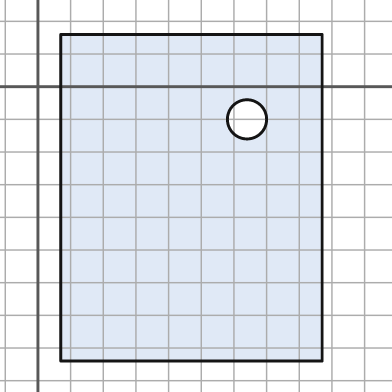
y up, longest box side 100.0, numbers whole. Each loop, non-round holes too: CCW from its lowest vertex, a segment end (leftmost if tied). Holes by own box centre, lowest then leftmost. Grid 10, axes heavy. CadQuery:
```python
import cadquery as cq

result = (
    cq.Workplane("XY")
    .moveTo(7.0, -84.0)
    .lineTo(87.0, -84.0)
    .lineTo(87.0, 16.0)
    .lineTo(7.0, 16.0)
    .close()
    .moveTo(64.0, -10.0)
    .circle(6.0)
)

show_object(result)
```